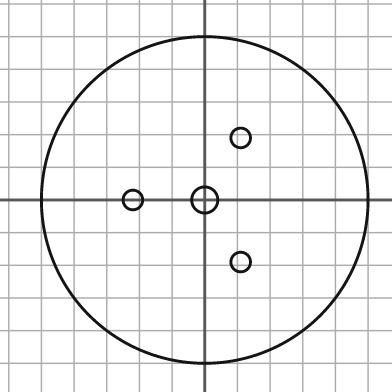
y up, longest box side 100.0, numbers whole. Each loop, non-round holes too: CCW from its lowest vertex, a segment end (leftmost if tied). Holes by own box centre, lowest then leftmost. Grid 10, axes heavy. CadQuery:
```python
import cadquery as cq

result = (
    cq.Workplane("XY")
    .moveTo(0.0, 0.0)
    .circle(50.0)
    .moveTo(11.0, -19.0)
    .circle(3.0)
    .moveTo(-22.0, 0.0)
    .circle(3.0)
    .moveTo(0.0, 0.0)
    .circle(4.0)
    .moveTo(11.0, 19.0)
    .circle(3.0)
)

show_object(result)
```